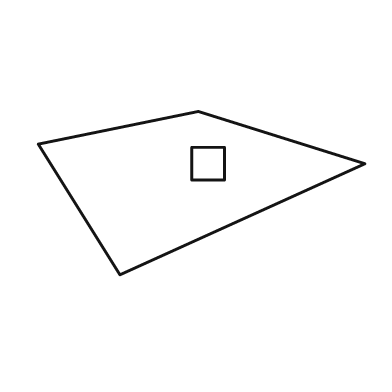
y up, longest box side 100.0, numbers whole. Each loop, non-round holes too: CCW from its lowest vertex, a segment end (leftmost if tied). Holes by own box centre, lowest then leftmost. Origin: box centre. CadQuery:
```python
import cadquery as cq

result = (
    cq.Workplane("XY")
    .moveTo(-25.0, -25.0)
    .lineTo(50.0, 9.0)
    .lineTo(-1.0, 25.0)
    .lineTo(-50.0, 15.0)
    .close()
    .moveTo(-3.0, 4.0)
    .lineTo(7.0, 4.0)
    .lineTo(7.0, 14.0)
    .lineTo(-3.0, 14.0)
    .close()
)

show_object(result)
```